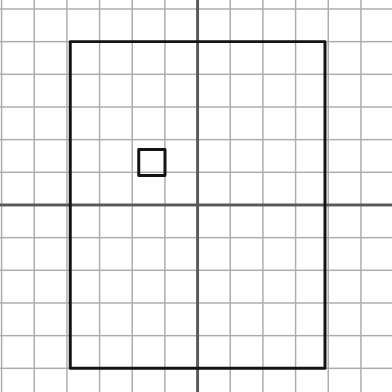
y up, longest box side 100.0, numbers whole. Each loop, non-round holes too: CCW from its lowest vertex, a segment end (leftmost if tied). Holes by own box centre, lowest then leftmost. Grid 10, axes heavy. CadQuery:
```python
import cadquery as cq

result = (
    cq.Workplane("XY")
    .moveTo(-39.0, -50.0)
    .lineTo(39.0, -50.0)
    .lineTo(39.0, 50.0)
    .lineTo(-39.0, 50.0)
    .close()
    .moveTo(-18.0, 9.0)
    .lineTo(-10.0, 9.0)
    .lineTo(-10.0, 17.0)
    .lineTo(-18.0, 17.0)
    .close()
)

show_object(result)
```